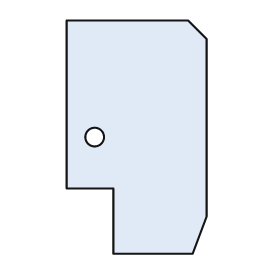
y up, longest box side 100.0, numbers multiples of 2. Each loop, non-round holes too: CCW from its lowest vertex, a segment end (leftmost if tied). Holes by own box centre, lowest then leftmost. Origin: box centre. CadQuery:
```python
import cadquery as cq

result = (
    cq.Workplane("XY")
    .moveTo(-10.0, -50.0)
    .lineTo(24.0, -50.0)
    .lineTo(30.0, -34.0)
    .lineTo(30.0, 42.0)
    .lineTo(22.0, 50.0)
    .lineTo(-30.0, 50.0)
    .lineTo(-30.0, -22.0)
    .lineTo(-10.0, -22.0)
    .close()
    .moveTo(-18.0, 0.0)
    .circle(4.0)
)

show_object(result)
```